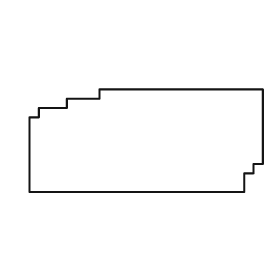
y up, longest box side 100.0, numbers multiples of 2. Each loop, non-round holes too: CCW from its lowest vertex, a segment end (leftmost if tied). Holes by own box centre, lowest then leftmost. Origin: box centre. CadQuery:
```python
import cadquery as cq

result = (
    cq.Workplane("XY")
    .moveTo(-50.0, -22.0)
    .lineTo(42.0, -22.0)
    .lineTo(42.0, -14.0)
    .lineTo(46.0, -14.0)
    .lineTo(46.0, -10.0)
    .lineTo(50.0, -10.0)
    .lineTo(50.0, 22.0)
    .lineTo(-20.0, 22.0)
    .lineTo(-20.0, 18.0)
    .lineTo(-34.0, 18.0)
    .lineTo(-34.0, 14.0)
    .lineTo(-46.0, 14.0)
    .lineTo(-46.0, 10.0)
    .lineTo(-50.0, 10.0)
    .close()
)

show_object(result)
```